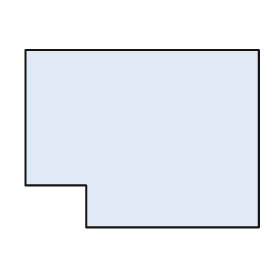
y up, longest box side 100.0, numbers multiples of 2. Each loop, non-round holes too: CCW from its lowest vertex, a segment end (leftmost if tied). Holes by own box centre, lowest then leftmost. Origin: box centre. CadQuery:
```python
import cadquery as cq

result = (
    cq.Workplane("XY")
    .moveTo(-24.0, -38.0)
    .lineTo(50.0, -38.0)
    .lineTo(50.0, 38.0)
    .lineTo(-50.0, 38.0)
    .lineTo(-50.0, -20.0)
    .lineTo(-24.0, -20.0)
    .close()
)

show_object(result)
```